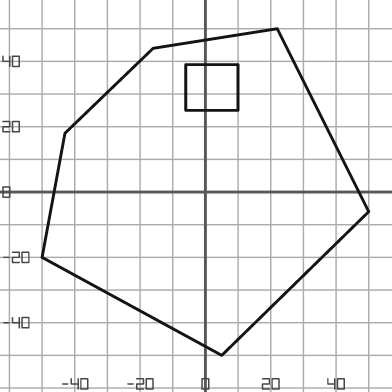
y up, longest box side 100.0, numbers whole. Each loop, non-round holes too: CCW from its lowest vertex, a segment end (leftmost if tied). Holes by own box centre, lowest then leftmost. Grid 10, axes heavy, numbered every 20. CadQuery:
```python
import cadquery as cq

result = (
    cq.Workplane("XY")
    .moveTo(5.0, -50.0)
    .lineTo(50.0, -6.0)
    .lineTo(22.0, 50.0)
    .lineTo(-16.0, 44.0)
    .lineTo(-43.0, 18.0)
    .lineTo(-50.0, -20.0)
    .close()
    .moveTo(-6.0, 25.0)
    .lineTo(10.0, 25.0)
    .lineTo(10.0, 39.0)
    .lineTo(-6.0, 39.0)
    .close()
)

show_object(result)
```